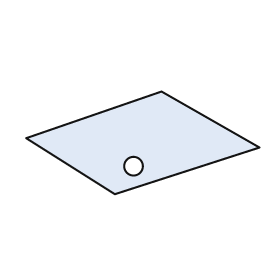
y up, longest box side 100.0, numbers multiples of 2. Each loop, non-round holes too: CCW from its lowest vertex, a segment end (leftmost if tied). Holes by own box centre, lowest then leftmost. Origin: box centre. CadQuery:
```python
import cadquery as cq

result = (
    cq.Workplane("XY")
    .moveTo(-12.0, -22.0)
    .lineTo(50.0, -2.0)
    .lineTo(8.0, 22.0)
    .lineTo(-50.0, 2.0)
    .close()
    .moveTo(-4.0, -10.0)
    .circle(4.0)
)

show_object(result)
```